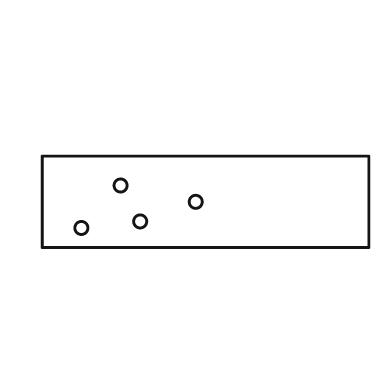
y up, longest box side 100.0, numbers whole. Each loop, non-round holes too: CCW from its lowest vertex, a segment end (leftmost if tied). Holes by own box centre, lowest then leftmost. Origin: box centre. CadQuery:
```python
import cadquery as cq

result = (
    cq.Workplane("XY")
    .moveTo(-50.0, -14.0)
    .lineTo(50.0, -14.0)
    .lineTo(50.0, 14.0)
    .lineTo(-50.0, 14.0)
    .close()
    .moveTo(-38.0, -8.0)
    .circle(2.0)
    .moveTo(-20.0, -6.0)
    .circle(2.0)
    .moveTo(-3.0, 0.0)
    .circle(2.0)
    .moveTo(-26.0, 5.0)
    .circle(2.0)
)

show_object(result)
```